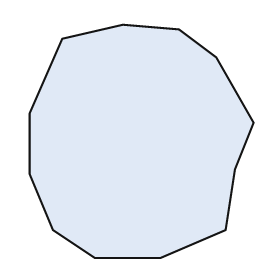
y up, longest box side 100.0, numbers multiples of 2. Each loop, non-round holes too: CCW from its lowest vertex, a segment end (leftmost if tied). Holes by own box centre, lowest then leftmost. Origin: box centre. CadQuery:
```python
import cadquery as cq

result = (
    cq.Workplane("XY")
    .moveTo(-20.0, -50.0)
    .lineTo(8.0, -50.0)
    .lineTo(36.0, -38.0)
    .lineTo(40.0, -12.0)
    .lineTo(48.0, 8.0)
    .lineTo(32.0, 36.0)
    .lineTo(16.0, 48.0)
    .lineTo(-8.0, 50.0)
    .lineTo(-34.0, 44.0)
    .lineTo(-48.0, 12.0)
    .lineTo(-48.0, -14.0)
    .lineTo(-38.0, -38.0)
    .close()
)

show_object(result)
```